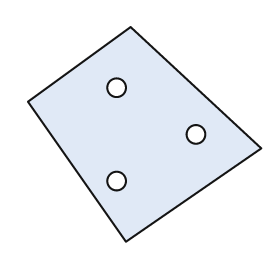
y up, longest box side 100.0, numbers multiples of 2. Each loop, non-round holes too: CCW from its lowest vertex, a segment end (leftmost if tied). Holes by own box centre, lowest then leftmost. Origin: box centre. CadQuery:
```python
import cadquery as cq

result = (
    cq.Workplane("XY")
    .moveTo(-8.0, -46.0)
    .lineTo(50.0, -6.0)
    .lineTo(-6.0, 46.0)
    .lineTo(-50.0, 14.0)
    .close()
    .moveTo(-12.0, -20.0)
    .circle(4.0)
    .moveTo(22.0, 0.0)
    .circle(4.0)
    .moveTo(-12.0, 20.0)
    .circle(4.0)
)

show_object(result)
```